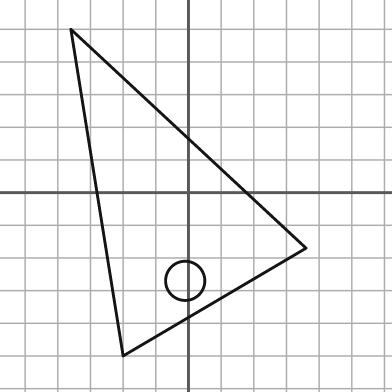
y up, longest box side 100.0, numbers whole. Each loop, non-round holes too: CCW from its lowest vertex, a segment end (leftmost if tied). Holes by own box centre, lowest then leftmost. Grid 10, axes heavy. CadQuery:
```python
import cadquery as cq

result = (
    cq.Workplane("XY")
    .moveTo(-20.0, -50.0)
    .lineTo(36.0, -17.0)
    .lineTo(-36.0, 50.0)
    .close()
    .moveTo(-1.0, -27.0)
    .circle(6.0)
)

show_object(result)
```